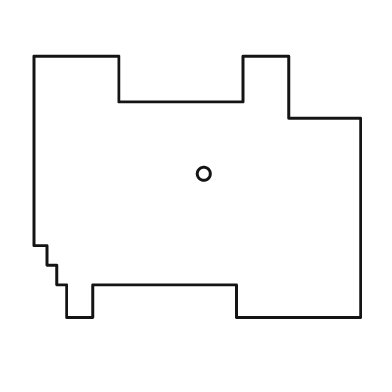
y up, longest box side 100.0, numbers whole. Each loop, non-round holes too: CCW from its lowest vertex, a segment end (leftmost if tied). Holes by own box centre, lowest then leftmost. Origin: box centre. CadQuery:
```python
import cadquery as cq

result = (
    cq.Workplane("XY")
    .moveTo(-40.0, -40.0)
    .lineTo(-32.0, -40.0)
    .lineTo(-32.0, -30.0)
    .lineTo(12.0, -30.0)
    .lineTo(12.0, -40.0)
    .lineTo(50.0, -40.0)
    .lineTo(50.0, 21.0)
    .lineTo(28.0, 21.0)
    .lineTo(28.0, 40.0)
    .lineTo(14.0, 40.0)
    .lineTo(14.0, 26.0)
    .lineTo(-24.0, 26.0)
    .lineTo(-24.0, 40.0)
    .lineTo(-50.0, 40.0)
    .lineTo(-50.0, -18.0)
    .lineTo(-46.0, -18.0)
    .lineTo(-46.0, -24.0)
    .lineTo(-43.0, -24.0)
    .lineTo(-43.0, -30.0)
    .lineTo(-40.0, -30.0)
    .close()
    .moveTo(2.0, 4.0)
    .circle(2.0)
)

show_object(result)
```